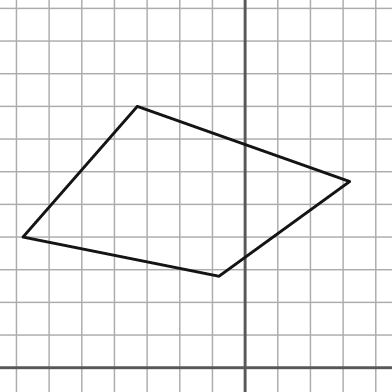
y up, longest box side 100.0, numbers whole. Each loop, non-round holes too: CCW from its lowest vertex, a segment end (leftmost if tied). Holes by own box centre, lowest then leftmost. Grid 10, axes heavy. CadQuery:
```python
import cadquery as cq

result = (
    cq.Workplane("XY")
    .moveTo(-8.0, 28.0)
    .lineTo(32.0, 57.0)
    .lineTo(-33.0, 80.0)
    .lineTo(-68.0, 40.0)
    .close()
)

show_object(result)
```